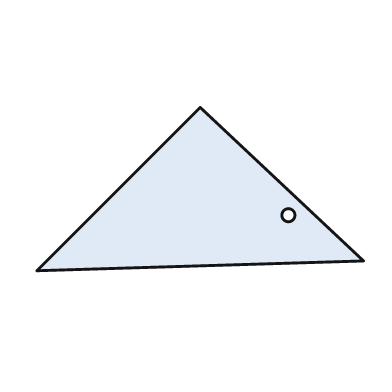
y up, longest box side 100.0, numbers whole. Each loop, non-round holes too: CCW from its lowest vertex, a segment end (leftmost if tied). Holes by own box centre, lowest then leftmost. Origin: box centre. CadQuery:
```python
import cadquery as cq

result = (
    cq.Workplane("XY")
    .moveTo(-50.0, -25.0)
    .lineTo(50.0, -22.0)
    .lineTo(0.0, 25.0)
    .close()
    .moveTo(27.0, -8.0)
    .circle(2.0)
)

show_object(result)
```